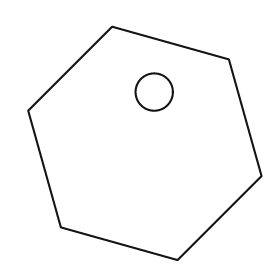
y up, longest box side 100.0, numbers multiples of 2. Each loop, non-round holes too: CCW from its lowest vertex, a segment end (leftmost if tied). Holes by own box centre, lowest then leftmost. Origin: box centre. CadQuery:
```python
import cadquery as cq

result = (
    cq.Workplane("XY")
    .moveTo(14.0, -50.0)
    .lineTo(50.0, -14.0)
    .lineTo(36.0, 36.0)
    .lineTo(-14.0, 50.0)
    .lineTo(-50.0, 14.0)
    .lineTo(-36.0, -36.0)
    .close()
    .moveTo(4.0, 22.0)
    .circle(8.0)
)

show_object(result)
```